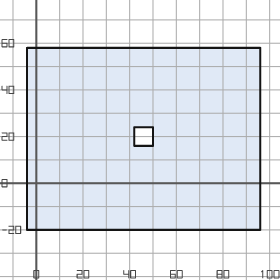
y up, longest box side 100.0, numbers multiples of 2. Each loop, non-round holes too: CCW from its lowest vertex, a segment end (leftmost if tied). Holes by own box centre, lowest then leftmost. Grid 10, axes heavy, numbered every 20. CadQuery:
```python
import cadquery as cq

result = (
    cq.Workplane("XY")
    .moveTo(-4.0, -20.0)
    .lineTo(96.0, -20.0)
    .lineTo(96.0, 58.0)
    .lineTo(-4.0, 58.0)
    .close()
    .moveTo(42.0, 16.0)
    .lineTo(50.0, 16.0)
    .lineTo(50.0, 24.0)
    .lineTo(42.0, 24.0)
    .close()
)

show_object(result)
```